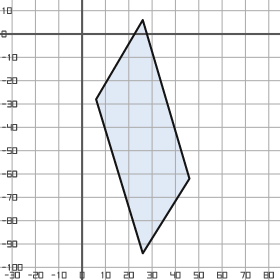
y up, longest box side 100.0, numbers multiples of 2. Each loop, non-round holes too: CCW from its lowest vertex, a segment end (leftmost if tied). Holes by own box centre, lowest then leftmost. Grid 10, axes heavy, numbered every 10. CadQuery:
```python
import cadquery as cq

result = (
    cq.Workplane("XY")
    .moveTo(26.0, -94.0)
    .lineTo(46.0, -62.0)
    .lineTo(26.0, 6.0)
    .lineTo(6.0, -28.0)
    .close()
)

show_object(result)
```